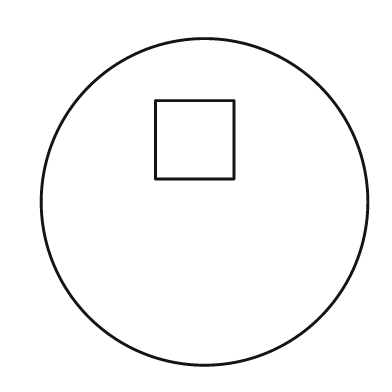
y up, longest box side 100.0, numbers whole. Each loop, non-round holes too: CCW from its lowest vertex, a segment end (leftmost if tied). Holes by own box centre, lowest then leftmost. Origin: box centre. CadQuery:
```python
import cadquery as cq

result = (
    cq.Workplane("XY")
    .moveTo(0.0, 0.0)
    .circle(50.0)
    .moveTo(-15.0, 7.0)
    .lineTo(9.0, 7.0)
    .lineTo(9.0, 31.0)
    .lineTo(-15.0, 31.0)
    .close()
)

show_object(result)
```